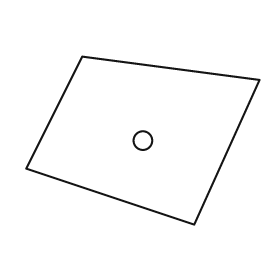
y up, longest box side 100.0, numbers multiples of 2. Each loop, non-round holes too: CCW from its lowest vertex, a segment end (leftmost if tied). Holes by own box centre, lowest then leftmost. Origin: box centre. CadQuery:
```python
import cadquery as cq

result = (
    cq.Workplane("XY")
    .moveTo(22.0, -36.0)
    .lineTo(50.0, 26.0)
    .lineTo(-26.0, 36.0)
    .lineTo(-50.0, -12.0)
    .close()
    .moveTo(0.0, 0.0)
    .circle(4.0)
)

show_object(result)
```